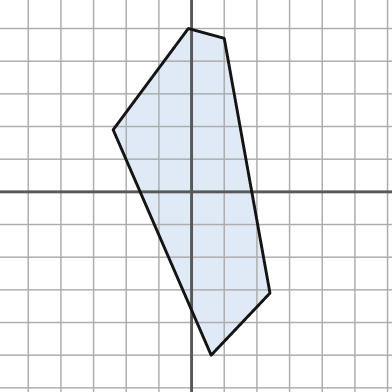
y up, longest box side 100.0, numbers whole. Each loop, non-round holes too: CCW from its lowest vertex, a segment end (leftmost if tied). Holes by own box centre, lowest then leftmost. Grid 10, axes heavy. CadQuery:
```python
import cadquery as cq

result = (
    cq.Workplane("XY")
    .moveTo(6.0, -50.0)
    .lineTo(24.0, -31.0)
    .lineTo(10.0, 47.0)
    .lineTo(-1.0, 50.0)
    .lineTo(-24.0, 19.0)
    .close()
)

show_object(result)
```